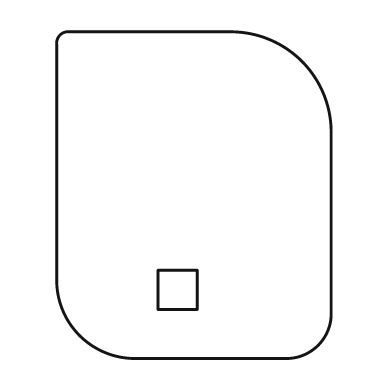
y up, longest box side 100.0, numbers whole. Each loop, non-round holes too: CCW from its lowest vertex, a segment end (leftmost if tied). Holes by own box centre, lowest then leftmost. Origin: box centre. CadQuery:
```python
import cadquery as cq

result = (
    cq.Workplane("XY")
    .moveTo(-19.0, -50.0)
    .lineTo(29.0, -50.0)
    .threePointArc((38.0, -46.0), (42.0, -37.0))
    .lineTo(42.0, 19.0)
    .threePointArc((33.0, 41.0), (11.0, 50.0))
    .lineTo(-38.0, 50.0)
    .threePointArc((-41.0, 49.0), (-42.0, 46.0))
    .lineTo(-42.0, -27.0)
    .threePointArc((-35.0, -43.0), (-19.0, -50.0))
    .close()
    .moveTo(-11.0, -35.0)
    .lineTo(1.0, -35.0)
    .lineTo(1.0, -23.0)
    .lineTo(-11.0, -23.0)
    .close()
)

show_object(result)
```